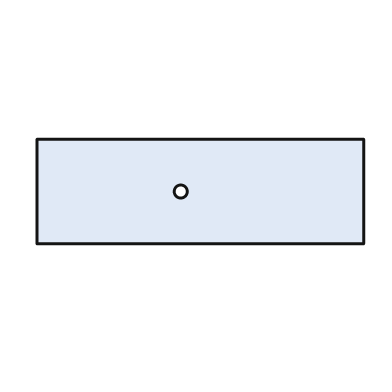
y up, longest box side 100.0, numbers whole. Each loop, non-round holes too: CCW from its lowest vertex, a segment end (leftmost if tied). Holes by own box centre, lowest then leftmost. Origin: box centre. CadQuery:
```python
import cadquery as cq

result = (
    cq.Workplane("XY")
    .moveTo(-50.0, -16.0)
    .lineTo(50.0, -16.0)
    .lineTo(50.0, 16.0)
    .lineTo(-50.0, 16.0)
    .close()
    .moveTo(-6.0, 0.0)
    .circle(2.0)
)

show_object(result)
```